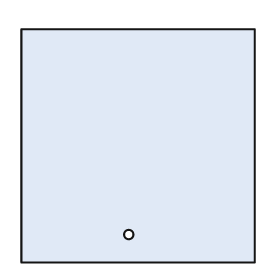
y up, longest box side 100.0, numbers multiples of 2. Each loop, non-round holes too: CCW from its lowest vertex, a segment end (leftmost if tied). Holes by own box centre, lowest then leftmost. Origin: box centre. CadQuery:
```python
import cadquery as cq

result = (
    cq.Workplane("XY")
    .moveTo(-50.0, -50.0)
    .lineTo(50.0, -50.0)
    .lineTo(50.0, 50.0)
    .lineTo(-50.0, 50.0)
    .close()
    .moveTo(-4.0, -38.0)
    .circle(2.0)
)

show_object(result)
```